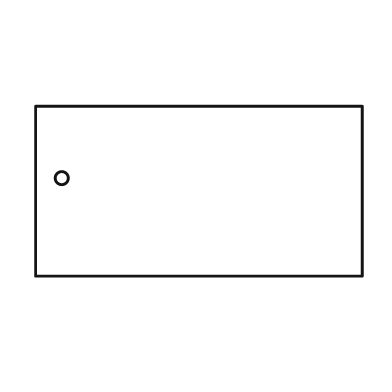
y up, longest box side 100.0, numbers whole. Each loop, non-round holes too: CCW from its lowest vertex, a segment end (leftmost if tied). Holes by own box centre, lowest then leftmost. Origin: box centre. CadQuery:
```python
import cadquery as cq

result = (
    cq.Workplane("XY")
    .moveTo(-50.0, -26.0)
    .lineTo(50.0, -26.0)
    .lineTo(50.0, 26.0)
    .lineTo(-50.0, 26.0)
    .close()
    .moveTo(-42.0, 4.0)
    .circle(2.0)
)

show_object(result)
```